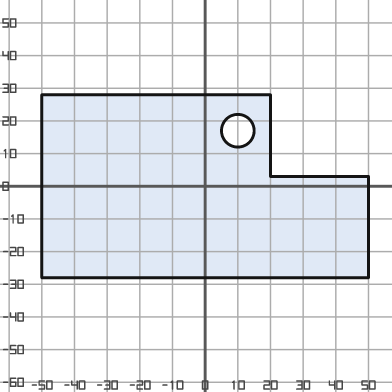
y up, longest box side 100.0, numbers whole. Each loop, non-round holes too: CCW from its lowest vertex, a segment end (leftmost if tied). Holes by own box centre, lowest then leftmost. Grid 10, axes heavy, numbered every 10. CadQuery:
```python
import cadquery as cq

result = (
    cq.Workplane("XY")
    .moveTo(-50.0, -28.0)
    .lineTo(50.0, -28.0)
    .lineTo(50.0, 3.0)
    .lineTo(20.0, 3.0)
    .lineTo(20.0, 28.0)
    .lineTo(-50.0, 28.0)
    .close()
    .moveTo(10.0, 17.0)
    .circle(5.0)
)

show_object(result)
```